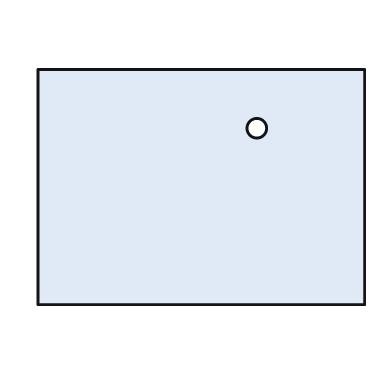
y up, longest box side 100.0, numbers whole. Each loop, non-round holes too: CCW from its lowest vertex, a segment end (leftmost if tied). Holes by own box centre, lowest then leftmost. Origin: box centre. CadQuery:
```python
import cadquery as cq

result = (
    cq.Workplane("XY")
    .moveTo(-50.0, -36.0)
    .lineTo(50.0, -36.0)
    .lineTo(50.0, 36.0)
    .lineTo(-50.0, 36.0)
    .close()
    .moveTo(17.0, 18.0)
    .circle(3.0)
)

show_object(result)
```